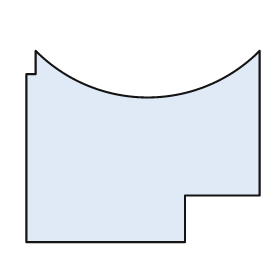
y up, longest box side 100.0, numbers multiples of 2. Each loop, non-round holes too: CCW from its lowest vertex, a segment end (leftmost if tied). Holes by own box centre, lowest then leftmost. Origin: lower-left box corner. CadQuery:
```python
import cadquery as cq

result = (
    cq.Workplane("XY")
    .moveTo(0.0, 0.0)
    .lineTo(68.0, 0.0)
    .lineTo(68.0, 20.0)
    .lineTo(100.0, 20.0)
    .lineTo(100.0, 82.0)
    .threePointArc((52.0, 62.0), (4.0, 82.0))
    .lineTo(4.0, 72.0)
    .lineTo(0.0, 72.0)
    .close()
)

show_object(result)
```